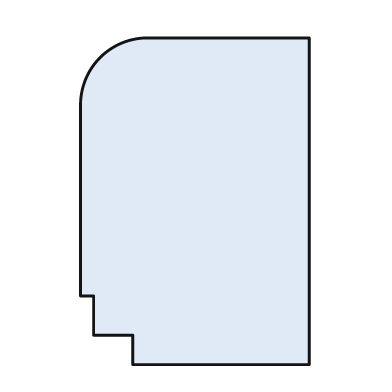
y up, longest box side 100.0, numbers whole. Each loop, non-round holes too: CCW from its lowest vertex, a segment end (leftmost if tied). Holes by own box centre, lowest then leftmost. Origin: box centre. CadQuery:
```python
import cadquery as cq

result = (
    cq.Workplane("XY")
    .moveTo(-19.0, -50.0)
    .lineTo(35.0, -50.0)
    .lineTo(35.0, 50.0)
    .lineTo(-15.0, 50.0)
    .threePointArc((-29.0, 44.0), (-35.0, 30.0))
    .lineTo(-35.0, -29.0)
    .lineTo(-31.0, -29.0)
    .lineTo(-31.0, -41.0)
    .lineTo(-19.0, -41.0)
    .close()
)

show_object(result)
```